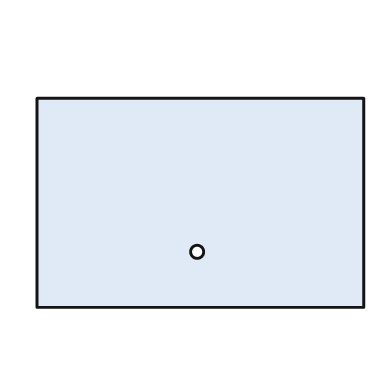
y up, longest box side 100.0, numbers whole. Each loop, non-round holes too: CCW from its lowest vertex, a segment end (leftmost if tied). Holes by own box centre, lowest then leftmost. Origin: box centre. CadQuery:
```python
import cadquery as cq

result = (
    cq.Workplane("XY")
    .moveTo(-50.0, -32.0)
    .lineTo(50.0, -32.0)
    .lineTo(50.0, 32.0)
    .lineTo(-50.0, 32.0)
    .close()
    .moveTo(-1.0, -15.0)
    .circle(2.0)
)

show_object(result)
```